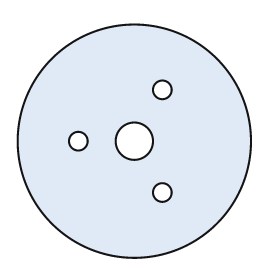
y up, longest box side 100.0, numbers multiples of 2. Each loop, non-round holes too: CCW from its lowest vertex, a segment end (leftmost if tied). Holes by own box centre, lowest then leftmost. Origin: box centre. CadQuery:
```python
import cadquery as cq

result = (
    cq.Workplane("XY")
    .moveTo(0.0, 0.0)
    .circle(50.0)
    .moveTo(12.0, -22.0)
    .circle(4.0)
    .moveTo(-24.0, 0.0)
    .circle(4.0)
    .moveTo(0.0, 0.0)
    .circle(8.0)
    .moveTo(12.0, 22.0)
    .circle(4.0)
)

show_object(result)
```